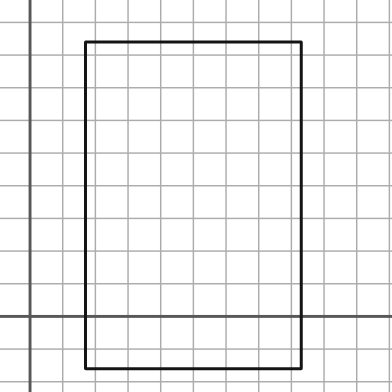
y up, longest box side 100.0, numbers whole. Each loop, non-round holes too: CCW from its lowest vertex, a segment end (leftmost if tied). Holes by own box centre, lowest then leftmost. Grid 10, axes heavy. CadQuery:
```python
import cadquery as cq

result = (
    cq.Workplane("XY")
    .moveTo(17.0, -16.0)
    .lineTo(83.0, -16.0)
    .lineTo(83.0, 84.0)
    .lineTo(17.0, 84.0)
    .close()
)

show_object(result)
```